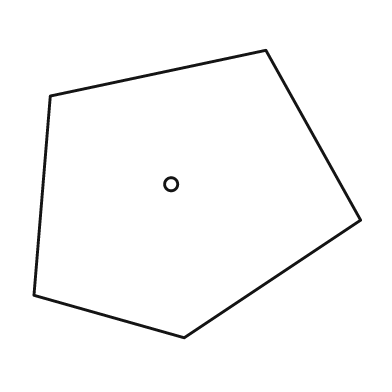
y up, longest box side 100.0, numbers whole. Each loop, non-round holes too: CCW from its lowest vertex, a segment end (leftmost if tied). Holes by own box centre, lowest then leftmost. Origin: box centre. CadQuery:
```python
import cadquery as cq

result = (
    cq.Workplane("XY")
    .moveTo(-4.0, -44.0)
    .lineTo(50.0, -8.0)
    .lineTo(21.0, 44.0)
    .lineTo(-45.0, 30.0)
    .lineTo(-50.0, -31.0)
    .close()
    .moveTo(-8.0, 3.0)
    .circle(2.0)
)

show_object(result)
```